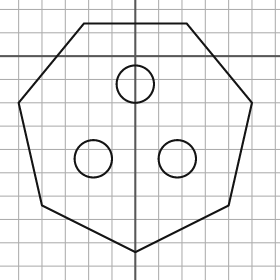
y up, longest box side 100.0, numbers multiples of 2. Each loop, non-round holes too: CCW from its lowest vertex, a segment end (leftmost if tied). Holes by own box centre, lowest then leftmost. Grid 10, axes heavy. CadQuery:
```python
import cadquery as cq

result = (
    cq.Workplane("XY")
    .moveTo(0.0, -84.0)
    .lineTo(40.0, -64.0)
    .lineTo(50.0, -20.0)
    .lineTo(22.0, 14.0)
    .lineTo(-22.0, 14.0)
    .lineTo(-50.0, -20.0)
    .lineTo(-40.0, -64.0)
    .close()
    .moveTo(-18.0, -44.0)
    .circle(8.0)
    .moveTo(18.0, -44.0)
    .circle(8.0)
    .moveTo(0.0, -12.0)
    .circle(8.0)
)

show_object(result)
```